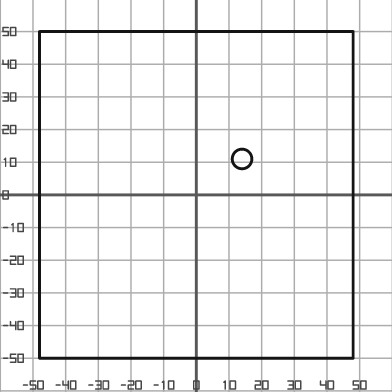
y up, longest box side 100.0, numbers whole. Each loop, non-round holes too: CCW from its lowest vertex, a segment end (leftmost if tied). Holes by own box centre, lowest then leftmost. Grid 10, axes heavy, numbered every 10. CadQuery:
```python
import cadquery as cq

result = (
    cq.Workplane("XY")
    .moveTo(-48.0, -50.0)
    .lineTo(48.0, -50.0)
    .lineTo(48.0, 50.0)
    .lineTo(-48.0, 50.0)
    .close()
    .moveTo(14.0, 11.0)
    .circle(3.0)
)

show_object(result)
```